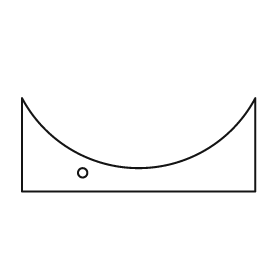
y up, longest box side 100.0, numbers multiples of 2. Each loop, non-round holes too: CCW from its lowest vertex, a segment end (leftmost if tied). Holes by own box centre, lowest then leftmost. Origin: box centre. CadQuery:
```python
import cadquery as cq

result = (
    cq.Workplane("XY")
    .moveTo(-50.0, -20.0)
    .lineTo(50.0, -20.0)
    .lineTo(50.0, 20.0)
    .threePointArc((0.0, -10.0), (-50.0, 20.0))
    .close()
    .moveTo(-24.0, -12.0)
    .circle(2.0)
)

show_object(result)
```